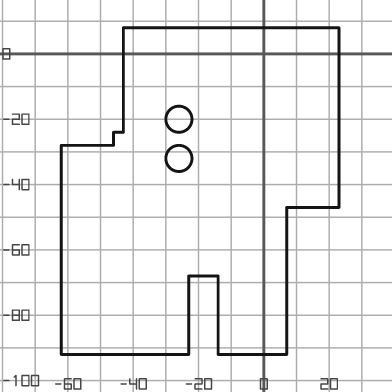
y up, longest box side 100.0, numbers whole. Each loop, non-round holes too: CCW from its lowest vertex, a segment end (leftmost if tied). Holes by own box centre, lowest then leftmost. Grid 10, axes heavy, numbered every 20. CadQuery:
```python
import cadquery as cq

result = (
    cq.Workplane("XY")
    .moveTo(-62.0, -92.0)
    .lineTo(-23.0, -92.0)
    .lineTo(-23.0, -68.0)
    .lineTo(-14.0, -68.0)
    .lineTo(-14.0, -92.0)
    .lineTo(7.0, -92.0)
    .lineTo(7.0, -47.0)
    .lineTo(23.0, -47.0)
    .lineTo(23.0, 8.0)
    .lineTo(-43.0, 8.0)
    .lineTo(-43.0, -24.0)
    .lineTo(-46.0, -24.0)
    .lineTo(-46.0, -28.0)
    .lineTo(-62.0, -28.0)
    .close()
    .moveTo(-26.0, -32.0)
    .circle(4.0)
    .moveTo(-26.0, -20.0)
    .circle(4.0)
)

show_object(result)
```